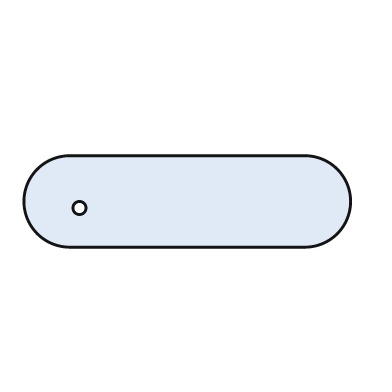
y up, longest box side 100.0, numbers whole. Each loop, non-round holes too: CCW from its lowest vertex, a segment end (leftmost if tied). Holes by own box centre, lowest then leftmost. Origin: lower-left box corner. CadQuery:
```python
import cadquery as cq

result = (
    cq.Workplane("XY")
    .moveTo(14.0, 0.0)
    .lineTo(86.0, 0.0)
    .threePointArc((100.0, 14.0), (86.0, 28.0))
    .lineTo(14.0, 28.0)
    .threePointArc((0.0, 14.0), (14.0, 0.0))
    .close()
    .moveTo(17.0, 12.0)
    .circle(2.0)
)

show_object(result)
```